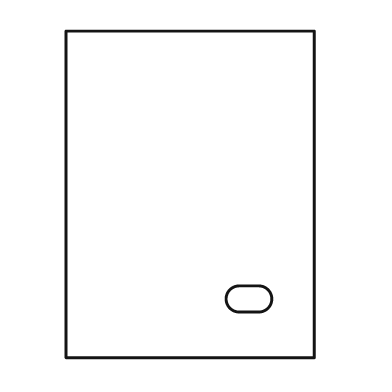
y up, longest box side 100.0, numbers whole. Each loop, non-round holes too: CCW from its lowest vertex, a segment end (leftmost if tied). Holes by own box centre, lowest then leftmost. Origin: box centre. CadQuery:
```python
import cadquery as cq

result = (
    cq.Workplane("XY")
    .moveTo(-38.0, -50.0)
    .lineTo(38.0, -50.0)
    .lineTo(38.0, 50.0)
    .lineTo(-38.0, 50.0)
    .close()
    .moveTo(15.0, -36.0)
    .lineTo(21.0, -36.0)
    .threePointArc((25.0, -32.0), (21.0, -28.0))
    .lineTo(15.0, -28.0)
    .threePointArc((11.0, -32.0), (15.0, -36.0))
    .close()
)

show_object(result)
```